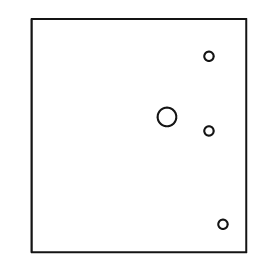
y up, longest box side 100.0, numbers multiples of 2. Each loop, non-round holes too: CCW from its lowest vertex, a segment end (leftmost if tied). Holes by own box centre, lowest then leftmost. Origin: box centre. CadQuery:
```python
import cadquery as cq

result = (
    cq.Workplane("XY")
    .moveTo(-46.0, -50.0)
    .lineTo(46.0, -50.0)
    .lineTo(46.0, 50.0)
    .lineTo(-46.0, 50.0)
    .close()
    .moveTo(36.0, -38.0)
    .circle(2.0)
    .moveTo(30.0, 2.0)
    .circle(2.0)
    .moveTo(12.0, 8.0)
    .circle(4.0)
    .moveTo(30.0, 34.0)
    .circle(2.0)
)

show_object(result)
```